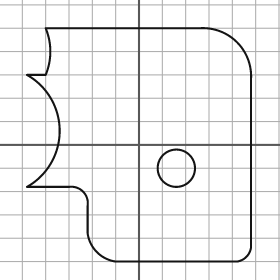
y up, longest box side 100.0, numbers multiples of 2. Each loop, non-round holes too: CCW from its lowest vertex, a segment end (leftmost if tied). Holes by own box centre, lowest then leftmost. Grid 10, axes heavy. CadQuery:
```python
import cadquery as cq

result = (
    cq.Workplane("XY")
    .moveTo(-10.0, -50.0)
    .lineTo(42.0, -50.0)
    .threePointArc((46.0, -48.0), (48.0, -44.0))
    .lineTo(48.0, 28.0)
    .threePointArc((42.0, 44.0), (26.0, 50.0))
    .lineTo(-40.0, 50.0)
    .threePointArc((-38.0, 40.0), (-40.0, 30.0))
    .lineTo(-48.0, 30.0)
    .threePointArc((-34.0, 6.0), (-48.0, -18.0))
    .lineTo(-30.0, -18.0)
    .threePointArc((-24.0, -20.0), (-22.0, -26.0))
    .lineTo(-22.0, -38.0)
    .threePointArc((-18.0, -46.0), (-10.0, -50.0))
    .close()
    .moveTo(16.0, -10.0)
    .circle(8.0)
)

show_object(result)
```